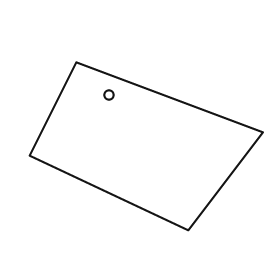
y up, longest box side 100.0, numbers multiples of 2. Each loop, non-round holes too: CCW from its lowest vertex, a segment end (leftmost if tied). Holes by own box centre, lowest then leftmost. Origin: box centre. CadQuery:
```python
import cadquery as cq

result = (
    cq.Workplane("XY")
    .moveTo(18.0, -36.0)
    .lineTo(50.0, 6.0)
    .lineTo(-30.0, 36.0)
    .lineTo(-50.0, -4.0)
    .close()
    .moveTo(-16.0, 22.0)
    .circle(2.0)
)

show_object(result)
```